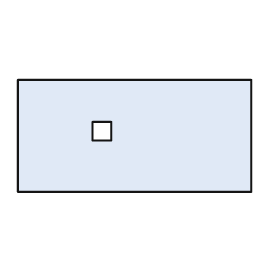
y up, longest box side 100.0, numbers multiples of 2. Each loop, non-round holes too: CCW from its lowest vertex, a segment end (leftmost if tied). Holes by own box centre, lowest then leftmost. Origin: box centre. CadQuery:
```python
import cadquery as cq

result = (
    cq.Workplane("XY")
    .moveTo(-50.0, -24.0)
    .lineTo(50.0, -24.0)
    .lineTo(50.0, 24.0)
    .lineTo(-50.0, 24.0)
    .close()
    .moveTo(-18.0, -2.0)
    .lineTo(-10.0, -2.0)
    .lineTo(-10.0, 6.0)
    .lineTo(-18.0, 6.0)
    .close()
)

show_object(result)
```